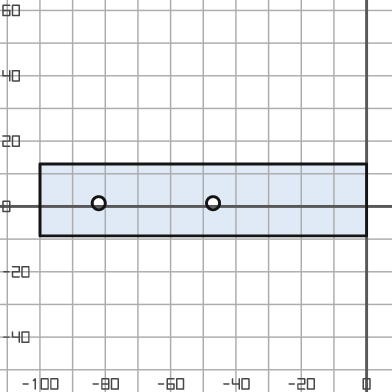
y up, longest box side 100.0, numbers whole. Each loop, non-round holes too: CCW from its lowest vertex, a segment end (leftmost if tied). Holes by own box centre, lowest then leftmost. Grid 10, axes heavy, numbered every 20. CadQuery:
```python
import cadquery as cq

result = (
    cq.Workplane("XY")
    .moveTo(-100.0, -9.0)
    .lineTo(0.0, -9.0)
    .lineTo(0.0, 13.0)
    .lineTo(-100.0, 13.0)
    .close()
    .moveTo(-82.0, 1.0)
    .circle(2.0)
    .moveTo(-47.0, 1.0)
    .circle(2.0)
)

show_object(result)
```